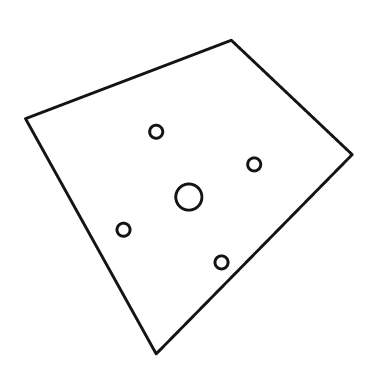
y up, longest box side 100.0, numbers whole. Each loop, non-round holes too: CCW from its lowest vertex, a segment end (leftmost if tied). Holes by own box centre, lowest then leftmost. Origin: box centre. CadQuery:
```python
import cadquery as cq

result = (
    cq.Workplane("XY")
    .moveTo(-10.0, -48.0)
    .lineTo(50.0, 13.0)
    .lineTo(13.0, 48.0)
    .lineTo(-50.0, 24.0)
    .close()
    .moveTo(10.0, -20.0)
    .circle(2.0)
    .moveTo(-20.0, -10.0)
    .circle(2.0)
    .moveTo(0.0, 0.0)
    .circle(4.0)
    .moveTo(20.0, 10.0)
    .circle(2.0)
    .moveTo(-10.0, 20.0)
    .circle(2.0)
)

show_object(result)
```